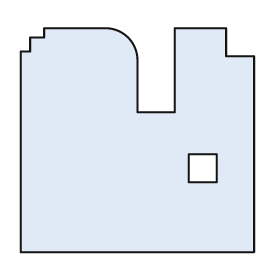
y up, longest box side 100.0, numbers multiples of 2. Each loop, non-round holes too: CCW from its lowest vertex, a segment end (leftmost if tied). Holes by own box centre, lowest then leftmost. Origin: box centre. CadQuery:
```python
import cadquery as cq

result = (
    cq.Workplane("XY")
    .moveTo(-50.0, -48.0)
    .lineTo(50.0, -48.0)
    .lineTo(50.0, 36.0)
    .lineTo(38.0, 36.0)
    .lineTo(38.0, 48.0)
    .lineTo(16.0, 48.0)
    .lineTo(16.0, 12.0)
    .lineTo(0.0, 12.0)
    .lineTo(0.0, 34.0)
    .threePointArc((-4.0, 44.0), (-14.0, 48.0))
    .lineTo(-40.0, 48.0)
    .lineTo(-40.0, 44.0)
    .lineTo(-46.0, 44.0)
    .lineTo(-46.0, 38.0)
    .lineTo(-50.0, 38.0)
    .close()
    .moveTo(22.0, -18.0)
    .lineTo(34.0, -18.0)
    .lineTo(34.0, -6.0)
    .lineTo(22.0, -6.0)
    .close()
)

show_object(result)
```